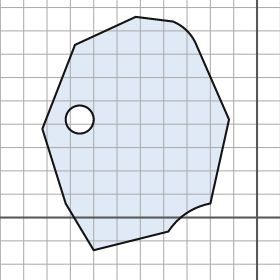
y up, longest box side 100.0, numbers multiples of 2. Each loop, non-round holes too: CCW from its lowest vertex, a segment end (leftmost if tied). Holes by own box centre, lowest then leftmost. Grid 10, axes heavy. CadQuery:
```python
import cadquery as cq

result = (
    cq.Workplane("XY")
    .moveTo(-70.0, -14.0)
    .lineTo(-38.0, -6.0)
    .threePointArc((-30.0, 2.0), (-20.0, 6.0))
    .lineTo(-12.0, 42.0)
    .lineTo(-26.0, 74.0)
    .threePointArc((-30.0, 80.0), (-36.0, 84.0))
    .lineTo(-52.0, 86.0)
    .lineTo(-78.0, 74.0)
    .lineTo(-92.0, 38.0)
    .lineTo(-82.0, 6.0)
    .close()
    .moveTo(-76.0, 42.0)
    .circle(6.0)
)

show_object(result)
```